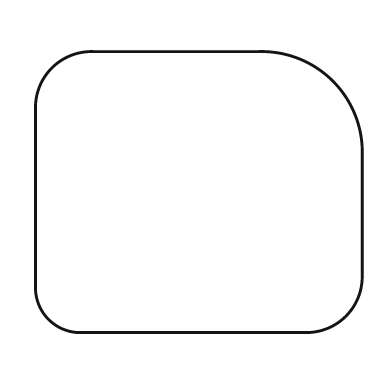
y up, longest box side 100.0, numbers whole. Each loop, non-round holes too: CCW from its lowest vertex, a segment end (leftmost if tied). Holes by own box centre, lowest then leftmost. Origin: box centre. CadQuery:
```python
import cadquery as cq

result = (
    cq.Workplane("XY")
    .moveTo(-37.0, -43.0)
    .lineTo(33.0, -43.0)
    .threePointArc((45.0, -38.0), (50.0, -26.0))
    .lineTo(50.0, 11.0)
    .threePointArc((41.0, 34.0), (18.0, 43.0))
    .lineTo(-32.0, 43.0)
    .threePointArc((-45.0, 38.0), (-50.0, 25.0))
    .lineTo(-50.0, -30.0)
    .threePointArc((-46.0, -39.0), (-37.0, -43.0))
    .close()
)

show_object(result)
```